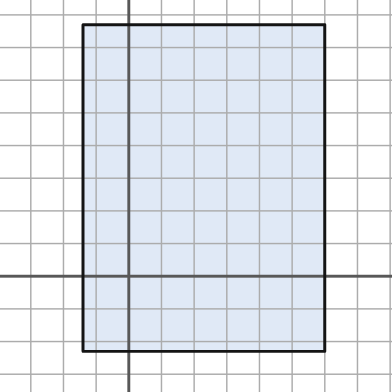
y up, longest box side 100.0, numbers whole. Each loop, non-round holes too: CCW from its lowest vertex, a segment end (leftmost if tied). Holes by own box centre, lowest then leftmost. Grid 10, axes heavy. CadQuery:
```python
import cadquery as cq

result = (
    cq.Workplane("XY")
    .moveTo(-14.0, -23.0)
    .lineTo(60.0, -23.0)
    .lineTo(60.0, 77.0)
    .lineTo(-14.0, 77.0)
    .close()
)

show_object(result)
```